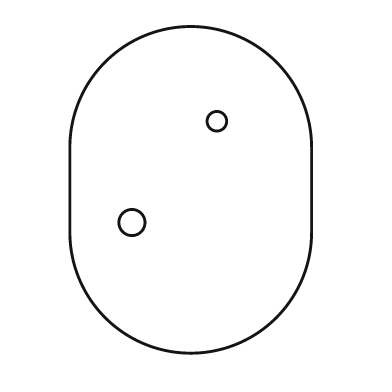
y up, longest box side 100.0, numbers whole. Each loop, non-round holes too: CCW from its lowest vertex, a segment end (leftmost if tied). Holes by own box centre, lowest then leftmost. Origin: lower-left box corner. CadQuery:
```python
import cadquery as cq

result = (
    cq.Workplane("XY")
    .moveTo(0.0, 37.0)
    .threePointArc((37.0, 0.0), (74.0, 37.0))
    .lineTo(74.0, 63.0)
    .threePointArc((37.0, 100.0), (0.0, 63.0))
    .close()
    .moveTo(19.0, 40.0)
    .circle(4.0)
    .moveTo(45.0, 71.0)
    .circle(3.0)
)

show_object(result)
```